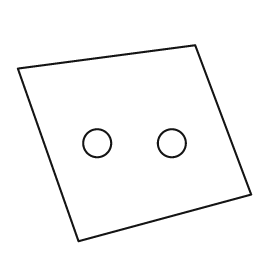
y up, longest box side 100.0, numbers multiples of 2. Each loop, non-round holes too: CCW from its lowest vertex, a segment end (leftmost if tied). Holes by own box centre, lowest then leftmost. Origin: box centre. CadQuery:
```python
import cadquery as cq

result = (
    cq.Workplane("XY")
    .moveTo(-24.0, -42.0)
    .lineTo(50.0, -22.0)
    .lineTo(26.0, 42.0)
    .lineTo(-50.0, 32.0)
    .close()
    .moveTo(-16.0, 0.0)
    .circle(6.0)
    .moveTo(16.0, 0.0)
    .circle(6.0)
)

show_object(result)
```